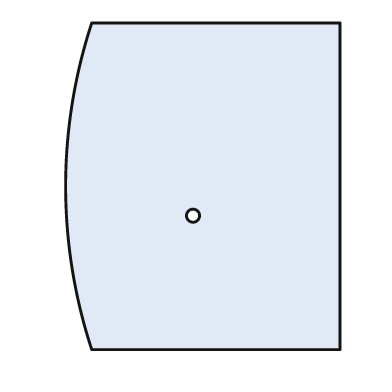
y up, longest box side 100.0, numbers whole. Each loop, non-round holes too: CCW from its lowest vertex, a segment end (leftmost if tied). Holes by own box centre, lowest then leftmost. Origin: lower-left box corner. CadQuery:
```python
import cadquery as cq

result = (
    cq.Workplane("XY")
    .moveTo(8.0, 0.0)
    .lineTo(84.0, 0.0)
    .lineTo(84.0, 100.0)
    .lineTo(8.0, 100.0)
    .threePointArc((0.0, 50.0), (8.0, 0.0))
    .close()
    .moveTo(39.0, 41.0)
    .circle(2.0)
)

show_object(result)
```